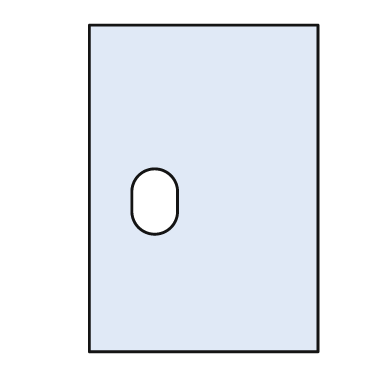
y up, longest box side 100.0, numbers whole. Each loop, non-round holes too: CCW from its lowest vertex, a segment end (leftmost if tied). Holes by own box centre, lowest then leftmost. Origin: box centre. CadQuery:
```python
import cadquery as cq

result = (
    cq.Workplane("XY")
    .moveTo(-35.0, -50.0)
    .lineTo(35.0, -50.0)
    .lineTo(35.0, 50.0)
    .lineTo(-35.0, 50.0)
    .close()
    .moveTo(-22.0, -7.0)
    .threePointArc((-15.0, -14.0), (-8.0, -7.0))
    .lineTo(-8.0, -1.0)
    .threePointArc((-15.0, 6.0), (-22.0, -1.0))
    .close()
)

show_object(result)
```